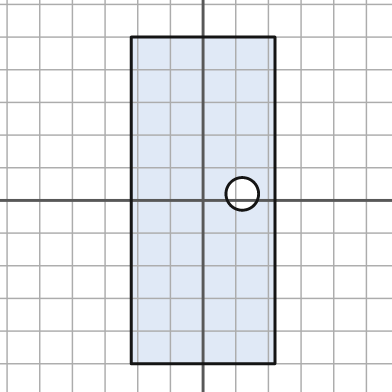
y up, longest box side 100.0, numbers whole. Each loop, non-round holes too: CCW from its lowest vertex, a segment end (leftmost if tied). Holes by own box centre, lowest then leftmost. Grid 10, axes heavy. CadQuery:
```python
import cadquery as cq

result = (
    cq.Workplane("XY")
    .moveTo(-22.0, -50.0)
    .lineTo(22.0, -50.0)
    .lineTo(22.0, 50.0)
    .lineTo(-22.0, 50.0)
    .close()
    .moveTo(12.0, 2.0)
    .circle(5.0)
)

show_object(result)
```